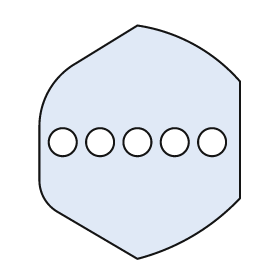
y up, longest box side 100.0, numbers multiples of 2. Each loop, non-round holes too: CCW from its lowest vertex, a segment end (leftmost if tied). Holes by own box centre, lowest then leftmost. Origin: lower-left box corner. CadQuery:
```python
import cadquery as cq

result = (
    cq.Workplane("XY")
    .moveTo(42.0, 0.0)
    .threePointArc((66.0, 10.0), (86.0, 26.0))
    .lineTo(86.0, 76.0)
    .threePointArc((66.0, 92.0), (42.0, 100.0))
    .lineTo(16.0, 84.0)
    .threePointArc((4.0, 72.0), (0.0, 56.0))
    .lineTo(0.0, 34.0)
    .threePointArc((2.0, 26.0), (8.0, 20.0))
    .close()
    .moveTo(10.0, 50.0)
    .circle(6.0)
    .moveTo(26.0, 50.0)
    .circle(6.0)
    .moveTo(42.0, 50.0)
    .circle(6.0)
    .moveTo(58.0, 50.0)
    .circle(6.0)
    .moveTo(74.0, 50.0)
    .circle(6.0)
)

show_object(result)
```